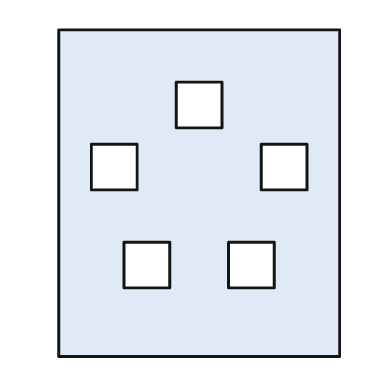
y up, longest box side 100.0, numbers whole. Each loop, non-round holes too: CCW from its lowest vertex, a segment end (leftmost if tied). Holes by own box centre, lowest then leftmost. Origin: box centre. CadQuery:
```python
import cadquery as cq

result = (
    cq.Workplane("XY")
    .moveTo(-43.0, -50.0)
    .lineTo(43.0, -50.0)
    .lineTo(43.0, 50.0)
    .lineTo(-43.0, 50.0)
    .close()
    .moveTo(-23.0, -29.0)
    .lineTo(-9.0, -29.0)
    .lineTo(-9.0, -15.0)
    .lineTo(-23.0, -15.0)
    .close()
    .moveTo(9.0, -29.0)
    .lineTo(23.0, -29.0)
    .lineTo(23.0, -15.0)
    .lineTo(9.0, -15.0)
    .close()
    .moveTo(-33.0, 1.0)
    .lineTo(-19.0, 1.0)
    .lineTo(-19.0, 15.0)
    .lineTo(-33.0, 15.0)
    .close()
    .moveTo(19.0, 1.0)
    .lineTo(33.0, 1.0)
    .lineTo(33.0, 15.0)
    .lineTo(19.0, 15.0)
    .close()
    .moveTo(-7.0, 20.0)
    .lineTo(7.0, 20.0)
    .lineTo(7.0, 34.0)
    .lineTo(-7.0, 34.0)
    .close()
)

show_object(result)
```